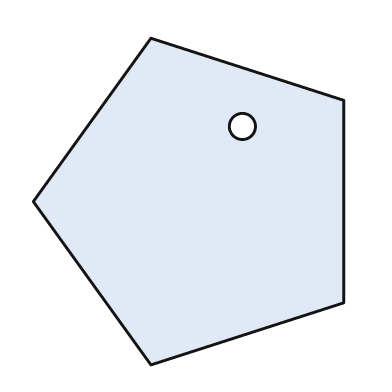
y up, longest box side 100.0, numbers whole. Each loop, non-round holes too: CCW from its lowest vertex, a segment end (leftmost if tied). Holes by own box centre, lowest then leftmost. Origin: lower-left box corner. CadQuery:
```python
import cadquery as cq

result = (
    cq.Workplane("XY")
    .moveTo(36.0, 0.0)
    .lineTo(95.0, 19.0)
    .lineTo(95.0, 81.0)
    .lineTo(36.0, 100.0)
    .lineTo(0.0, 50.0)
    .close()
    .moveTo(64.0, 73.0)
    .circle(4.0)
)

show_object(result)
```